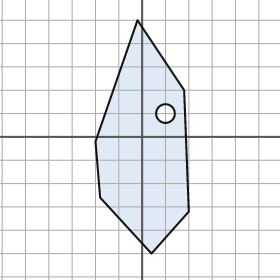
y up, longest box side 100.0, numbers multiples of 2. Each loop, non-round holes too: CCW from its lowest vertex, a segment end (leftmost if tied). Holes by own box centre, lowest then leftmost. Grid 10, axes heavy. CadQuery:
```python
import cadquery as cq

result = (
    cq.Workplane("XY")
    .moveTo(4.0, -50.0)
    .lineTo(20.0, -32.0)
    .lineTo(18.0, 20.0)
    .lineTo(-2.0, 50.0)
    .lineTo(-20.0, -2.0)
    .lineTo(-18.0, -26.0)
    .close()
    .moveTo(10.0, 10.0)
    .circle(4.0)
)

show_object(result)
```